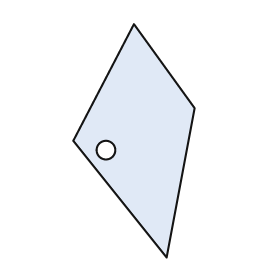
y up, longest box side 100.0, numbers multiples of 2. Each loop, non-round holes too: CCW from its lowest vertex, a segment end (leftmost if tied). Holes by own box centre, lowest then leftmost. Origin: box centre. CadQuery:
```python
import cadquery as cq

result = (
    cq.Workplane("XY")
    .moveTo(14.0, -50.0)
    .lineTo(26.0, 14.0)
    .lineTo(0.0, 50.0)
    .lineTo(-26.0, 0.0)
    .close()
    .moveTo(-12.0, -4.0)
    .circle(4.0)
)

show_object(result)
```